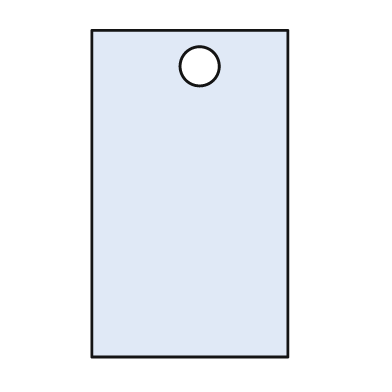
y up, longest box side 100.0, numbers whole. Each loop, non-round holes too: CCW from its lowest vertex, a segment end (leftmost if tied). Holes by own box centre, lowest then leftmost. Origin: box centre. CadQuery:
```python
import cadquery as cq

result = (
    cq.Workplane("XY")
    .moveTo(-30.0, -50.0)
    .lineTo(30.0, -50.0)
    .lineTo(30.0, 50.0)
    .lineTo(-30.0, 50.0)
    .close()
    .moveTo(3.0, 39.0)
    .circle(6.0)
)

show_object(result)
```